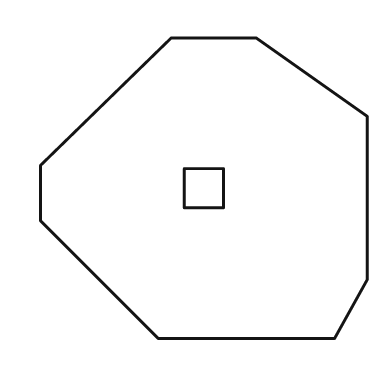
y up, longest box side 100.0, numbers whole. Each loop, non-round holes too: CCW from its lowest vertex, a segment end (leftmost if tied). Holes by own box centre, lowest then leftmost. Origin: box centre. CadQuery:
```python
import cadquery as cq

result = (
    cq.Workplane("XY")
    .moveTo(-14.0, -46.0)
    .lineTo(40.0, -46.0)
    .lineTo(50.0, -28.0)
    .lineTo(50.0, 22.0)
    .lineTo(16.0, 46.0)
    .lineTo(-10.0, 46.0)
    .lineTo(-50.0, 7.0)
    .lineTo(-50.0, -10.0)
    .close()
    .moveTo(-6.0, -6.0)
    .lineTo(6.0, -6.0)
    .lineTo(6.0, 6.0)
    .lineTo(-6.0, 6.0)
    .close()
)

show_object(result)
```